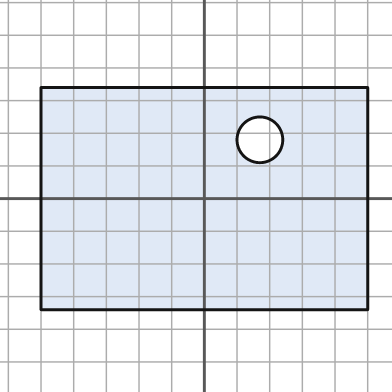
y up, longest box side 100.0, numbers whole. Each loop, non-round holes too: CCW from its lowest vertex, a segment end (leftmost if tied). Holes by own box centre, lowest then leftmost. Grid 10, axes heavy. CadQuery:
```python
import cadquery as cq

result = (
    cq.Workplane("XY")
    .moveTo(-50.0, -34.0)
    .lineTo(50.0, -34.0)
    .lineTo(50.0, 34.0)
    .lineTo(-50.0, 34.0)
    .close()
    .moveTo(17.0, 18.0)
    .circle(7.0)
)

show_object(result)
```